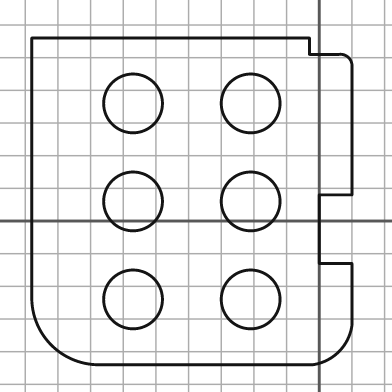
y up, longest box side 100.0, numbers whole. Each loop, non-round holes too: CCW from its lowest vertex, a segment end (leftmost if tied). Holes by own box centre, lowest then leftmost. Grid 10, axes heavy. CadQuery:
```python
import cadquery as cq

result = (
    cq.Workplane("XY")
    .moveTo(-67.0, -44.0)
    .lineTo(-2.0, -44.0)
    .threePointArc((6.0, -40.0), (10.0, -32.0))
    .lineTo(10.0, -13.0)
    .lineTo(0.0, -13.0)
    .lineTo(0.0, 8.0)
    .lineTo(10.0, 8.0)
    .lineTo(10.0, 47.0)
    .threePointArc((9.0, 50.0), (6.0, 51.0))
    .lineTo(-3.0, 51.0)
    .lineTo(-3.0, 56.0)
    .lineTo(-88.0, 56.0)
    .lineTo(-88.0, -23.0)
    .threePointArc((-82.0, -38.0), (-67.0, -44.0))
    .close()
    .moveTo(-57.0, -24.0)
    .circle(9.0)
    .moveTo(-21.0, -24.0)
    .circle(9.0)
    .moveTo(-57.0, 6.0)
    .circle(9.0)
    .moveTo(-21.0, 6.0)
    .circle(9.0)
    .moveTo(-57.0, 36.0)
    .circle(9.0)
    .moveTo(-21.0, 36.0)
    .circle(9.0)
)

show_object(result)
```